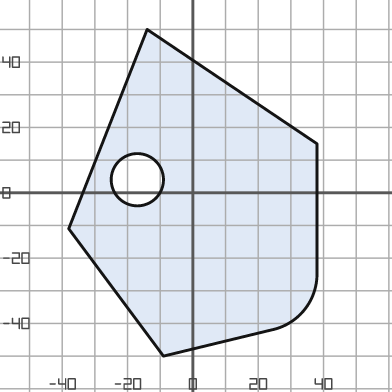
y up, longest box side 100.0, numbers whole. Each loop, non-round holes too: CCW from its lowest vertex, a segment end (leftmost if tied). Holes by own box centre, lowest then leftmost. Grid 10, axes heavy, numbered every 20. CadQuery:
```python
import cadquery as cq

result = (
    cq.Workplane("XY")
    .moveTo(-9.0, -50.0)
    .lineTo(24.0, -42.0)
    .threePointArc((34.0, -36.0), (38.0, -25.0))
    .lineTo(38.0, 15.0)
    .lineTo(-14.0, 50.0)
    .lineTo(-38.0, -11.0)
    .close()
    .moveTo(-17.0, 4.0)
    .circle(8.0)
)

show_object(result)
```